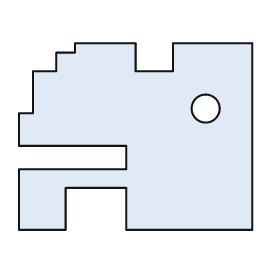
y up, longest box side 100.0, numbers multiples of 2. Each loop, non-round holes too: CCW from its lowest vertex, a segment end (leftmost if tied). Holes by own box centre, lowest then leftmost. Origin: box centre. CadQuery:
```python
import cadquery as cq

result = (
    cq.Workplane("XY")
    .moveTo(-50.0, -40.0)
    .lineTo(-30.0, -40.0)
    .lineTo(-30.0, -22.0)
    .lineTo(-4.0, -22.0)
    .lineTo(-4.0, -40.0)
    .lineTo(50.0, -40.0)
    .lineTo(50.0, 40.0)
    .lineTo(16.0, 40.0)
    .lineTo(16.0, 28.0)
    .lineTo(0.0, 28.0)
    .lineTo(0.0, 40.0)
    .lineTo(-26.0, 40.0)
    .lineTo(-26.0, 36.0)
    .lineTo(-34.0, 36.0)
    .lineTo(-34.0, 28.0)
    .lineTo(-44.0, 28.0)
    .lineTo(-44.0, 10.0)
    .lineTo(-50.0, 10.0)
    .lineTo(-50.0, -4.0)
    .lineTo(-4.0, -4.0)
    .lineTo(-4.0, -14.0)
    .lineTo(-50.0, -14.0)
    .close()
    .moveTo(30.0, 12.0)
    .circle(6.0)
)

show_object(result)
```